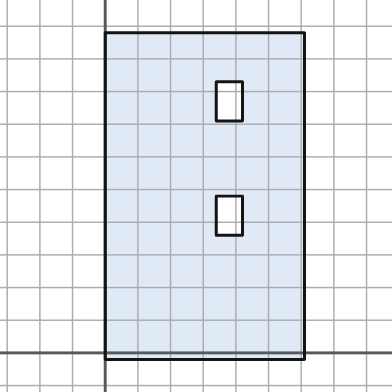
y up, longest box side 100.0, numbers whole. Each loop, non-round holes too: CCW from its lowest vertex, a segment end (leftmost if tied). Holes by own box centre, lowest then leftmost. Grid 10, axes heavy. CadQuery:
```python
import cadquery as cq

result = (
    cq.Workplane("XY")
    .moveTo(0.0, -2.0)
    .lineTo(61.0, -2.0)
    .lineTo(61.0, 98.0)
    .lineTo(0.0, 98.0)
    .close()
    .moveTo(34.0, 36.0)
    .lineTo(42.0, 36.0)
    .lineTo(42.0, 48.0)
    .lineTo(34.0, 48.0)
    .close()
    .moveTo(34.0, 71.0)
    .lineTo(42.0, 71.0)
    .lineTo(42.0, 83.0)
    .lineTo(34.0, 83.0)
    .close()
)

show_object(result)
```